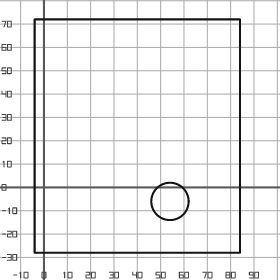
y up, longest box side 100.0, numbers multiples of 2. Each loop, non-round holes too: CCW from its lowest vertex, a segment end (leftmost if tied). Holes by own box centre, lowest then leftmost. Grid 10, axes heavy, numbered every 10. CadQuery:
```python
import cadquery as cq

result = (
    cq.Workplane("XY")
    .moveTo(-4.0, -28.0)
    .lineTo(84.0, -28.0)
    .lineTo(84.0, 72.0)
    .lineTo(-4.0, 72.0)
    .close()
    .moveTo(54.0, -6.0)
    .circle(8.0)
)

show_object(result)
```